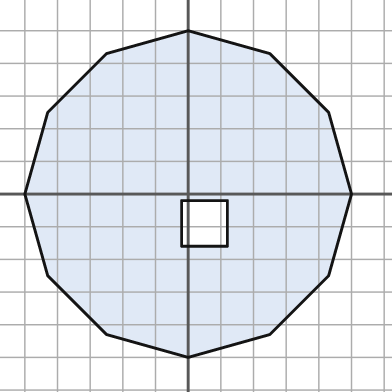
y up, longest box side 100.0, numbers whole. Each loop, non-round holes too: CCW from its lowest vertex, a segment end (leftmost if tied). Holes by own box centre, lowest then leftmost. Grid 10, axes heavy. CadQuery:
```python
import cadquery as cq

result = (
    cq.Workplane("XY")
    .moveTo(0.0, -50.0)
    .lineTo(25.0, -43.0)
    .lineTo(43.0, -25.0)
    .lineTo(50.0, 0.0)
    .lineTo(43.0, 25.0)
    .lineTo(25.0, 43.0)
    .lineTo(0.0, 50.0)
    .lineTo(-25.0, 43.0)
    .lineTo(-43.0, 25.0)
    .lineTo(-50.0, 0.0)
    .lineTo(-43.0, -25.0)
    .lineTo(-25.0, -43.0)
    .close()
    .moveTo(-2.0, -16.0)
    .lineTo(12.0, -16.0)
    .lineTo(12.0, -2.0)
    .lineTo(-2.0, -2.0)
    .close()
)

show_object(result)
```